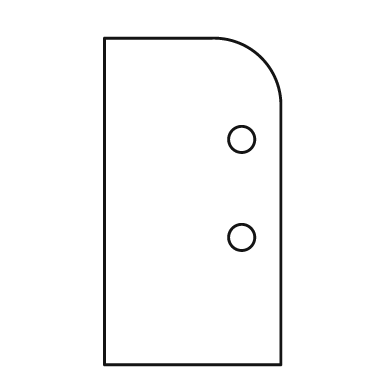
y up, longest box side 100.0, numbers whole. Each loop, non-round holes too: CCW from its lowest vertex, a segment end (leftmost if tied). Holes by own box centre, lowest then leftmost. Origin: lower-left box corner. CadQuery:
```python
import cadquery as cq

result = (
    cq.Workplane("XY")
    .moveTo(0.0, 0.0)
    .lineTo(54.0, 0.0)
    .lineTo(54.0, 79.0)
    .threePointArc((48.0, 94.0), (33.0, 100.0))
    .lineTo(0.0, 100.0)
    .close()
    .moveTo(42.0, 39.0)
    .circle(4.0)
    .moveTo(42.0, 69.0)
    .circle(4.0)
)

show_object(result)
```